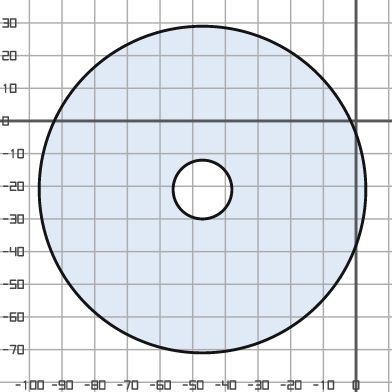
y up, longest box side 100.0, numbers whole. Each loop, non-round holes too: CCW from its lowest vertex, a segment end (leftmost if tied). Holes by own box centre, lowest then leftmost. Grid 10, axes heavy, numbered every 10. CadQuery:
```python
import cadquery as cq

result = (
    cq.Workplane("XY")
    .moveTo(-47.0, -21.0)
    .circle(50.0)
    .moveTo(-47.0, -21.0)
    .circle(9.0)
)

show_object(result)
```